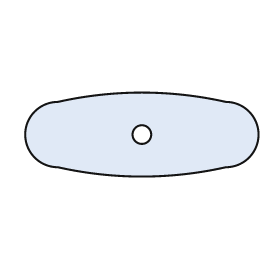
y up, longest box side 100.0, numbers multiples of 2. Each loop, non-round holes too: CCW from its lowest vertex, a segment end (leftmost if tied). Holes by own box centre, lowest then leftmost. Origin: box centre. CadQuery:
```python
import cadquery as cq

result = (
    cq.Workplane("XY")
    .moveTo(-36.0, -14.0)
    .threePointArc((0.0, -18.0), (36.0, -14.0))
    .threePointArc((50.0, 0.0), (36.0, 14.0))
    .threePointArc((0.0, 18.0), (-36.0, 14.0))
    .threePointArc((-50.0, 0.0), (-36.0, -14.0))
    .close()
    .moveTo(0.0, 0.0)
    .circle(4.0)
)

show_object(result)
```